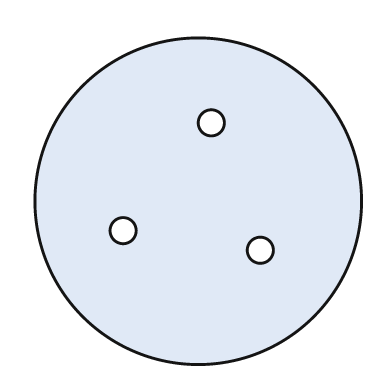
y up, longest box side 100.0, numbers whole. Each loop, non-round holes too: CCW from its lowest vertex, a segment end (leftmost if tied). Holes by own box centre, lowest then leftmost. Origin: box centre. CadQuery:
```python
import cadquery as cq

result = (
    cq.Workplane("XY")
    .moveTo(0.0, 0.0)
    .circle(50.0)
    .moveTo(19.0, -15.0)
    .circle(4.0)
    .moveTo(-23.0, -9.0)
    .circle(4.0)
    .moveTo(4.0, 24.0)
    .circle(4.0)
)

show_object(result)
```